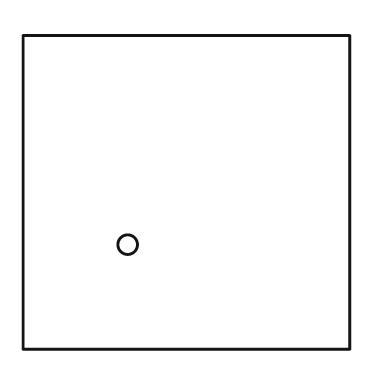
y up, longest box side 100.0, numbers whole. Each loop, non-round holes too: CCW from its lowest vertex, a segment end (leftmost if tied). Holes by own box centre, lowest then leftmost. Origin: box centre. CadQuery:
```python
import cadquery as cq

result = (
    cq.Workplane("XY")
    .moveTo(-50.0, -48.0)
    .lineTo(50.0, -48.0)
    .lineTo(50.0, 48.0)
    .lineTo(-50.0, 48.0)
    .close()
    .moveTo(-18.0, -16.0)
    .circle(3.0)
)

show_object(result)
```